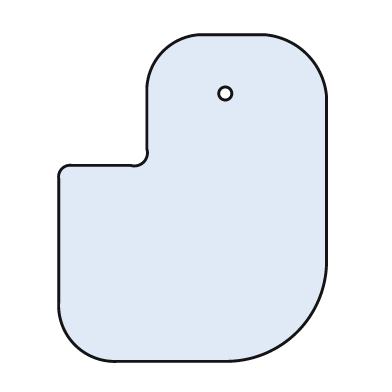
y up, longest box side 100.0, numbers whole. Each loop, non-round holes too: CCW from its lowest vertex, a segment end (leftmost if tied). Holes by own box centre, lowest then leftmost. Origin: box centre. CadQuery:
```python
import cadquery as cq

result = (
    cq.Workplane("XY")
    .moveTo(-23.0, -50.0)
    .lineTo(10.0, -50.0)
    .threePointArc((32.0, -41.0), (41.0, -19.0))
    .lineTo(41.0, 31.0)
    .threePointArc((35.0, 44.0), (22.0, 50.0))
    .lineTo(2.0, 50.0)
    .threePointArc((-9.0, 45.0), (-14.0, 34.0))
    .lineTo(-14.0, 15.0)
    .threePointArc((-15.0, 11.0), (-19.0, 10.0))
    .lineTo(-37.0, 10.0)
    .threePointArc((-40.0, 9.0), (-41.0, 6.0))
    .lineTo(-41.0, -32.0)
    .threePointArc((-36.0, -45.0), (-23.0, -50.0))
    .close()
    .moveTo(10.0, 32.0)
    .circle(2.0)
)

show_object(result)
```